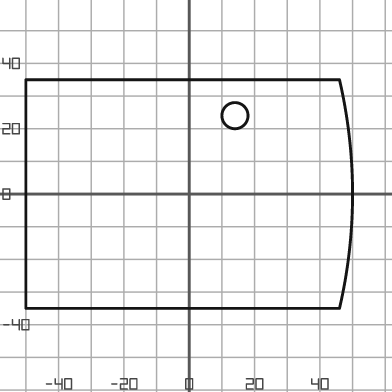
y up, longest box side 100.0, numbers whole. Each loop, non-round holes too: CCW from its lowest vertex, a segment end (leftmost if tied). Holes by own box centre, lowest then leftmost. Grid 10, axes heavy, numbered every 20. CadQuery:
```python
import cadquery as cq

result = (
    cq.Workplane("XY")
    .moveTo(-50.0, -35.0)
    .lineTo(46.0, -35.0)
    .threePointArc((50.0, 0.0), (46.0, 35.0))
    .lineTo(-50.0, 35.0)
    .close()
    .moveTo(14.0, 24.0)
    .circle(4.0)
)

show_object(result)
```